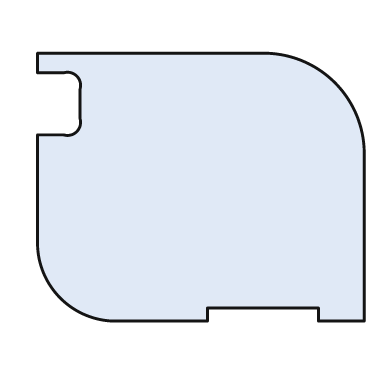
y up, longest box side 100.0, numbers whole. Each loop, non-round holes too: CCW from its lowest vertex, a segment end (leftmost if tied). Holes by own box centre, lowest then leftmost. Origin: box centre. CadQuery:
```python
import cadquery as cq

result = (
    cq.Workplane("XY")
    .moveTo(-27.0, -41.0)
    .lineTo(2.0, -41.0)
    .lineTo(2.0, -37.0)
    .lineTo(36.0, -37.0)
    .lineTo(36.0, -41.0)
    .lineTo(50.0, -41.0)
    .lineTo(50.0, 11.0)
    .threePointArc((41.0, 32.0), (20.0, 41.0))
    .lineTo(-50.0, 41.0)
    .lineTo(-50.0, 35.0)
    .lineTo(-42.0, 35.0)
    .threePointArc((-38.0, 34.0), (-37.0, 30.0))
    .lineTo(-37.0, 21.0)
    .threePointArc((-38.0, 17.0), (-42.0, 16.0))
    .lineTo(-50.0, 16.0)
    .lineTo(-50.0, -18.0)
    .threePointArc((-43.0, -34.0), (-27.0, -41.0))
    .close()
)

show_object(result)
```